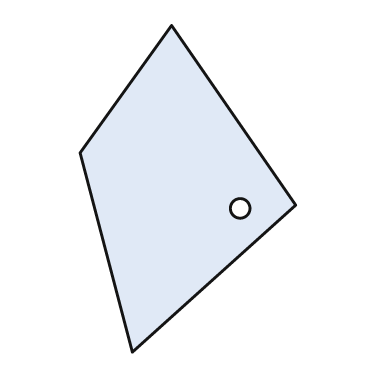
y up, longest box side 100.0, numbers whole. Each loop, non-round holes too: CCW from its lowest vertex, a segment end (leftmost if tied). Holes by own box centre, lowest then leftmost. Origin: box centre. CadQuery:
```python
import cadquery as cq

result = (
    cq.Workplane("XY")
    .moveTo(-17.0, -50.0)
    .lineTo(33.0, -5.0)
    .lineTo(-5.0, 50.0)
    .lineTo(-33.0, 11.0)
    .close()
    .moveTo(16.0, -6.0)
    .circle(3.0)
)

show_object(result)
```